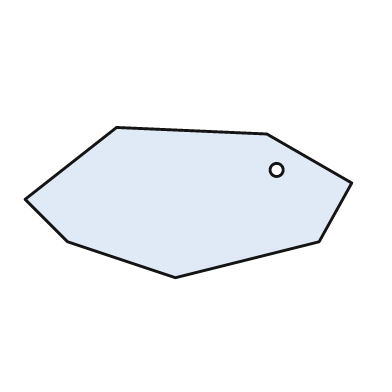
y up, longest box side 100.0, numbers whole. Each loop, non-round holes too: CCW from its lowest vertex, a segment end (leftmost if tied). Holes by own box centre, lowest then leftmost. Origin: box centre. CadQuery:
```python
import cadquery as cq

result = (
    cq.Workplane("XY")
    .moveTo(-4.0, -23.0)
    .lineTo(40.0, -12.0)
    .lineTo(50.0, 6.0)
    .lineTo(24.0, 21.0)
    .lineTo(-22.0, 23.0)
    .lineTo(-50.0, 1.0)
    .lineTo(-37.0, -12.0)
    .close()
    .moveTo(27.0, 10.0)
    .circle(2.0)
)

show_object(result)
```